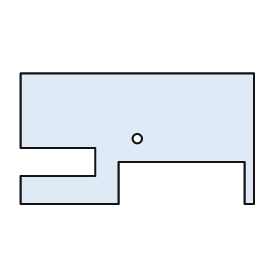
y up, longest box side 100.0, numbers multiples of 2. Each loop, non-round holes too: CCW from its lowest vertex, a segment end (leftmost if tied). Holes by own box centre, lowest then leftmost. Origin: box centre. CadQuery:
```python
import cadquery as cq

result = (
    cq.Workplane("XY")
    .moveTo(-50.0, -28.0)
    .lineTo(-8.0, -28.0)
    .lineTo(-8.0, -10.0)
    .lineTo(46.0, -10.0)
    .lineTo(46.0, -28.0)
    .lineTo(50.0, -28.0)
    .lineTo(50.0, 28.0)
    .lineTo(-50.0, 28.0)
    .lineTo(-50.0, -4.0)
    .lineTo(-18.0, -4.0)
    .lineTo(-18.0, -16.0)
    .lineTo(-50.0, -16.0)
    .close()
    .moveTo(0.0, 0.0)
    .circle(2.0)
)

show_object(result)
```